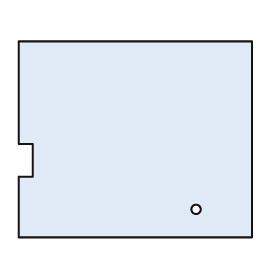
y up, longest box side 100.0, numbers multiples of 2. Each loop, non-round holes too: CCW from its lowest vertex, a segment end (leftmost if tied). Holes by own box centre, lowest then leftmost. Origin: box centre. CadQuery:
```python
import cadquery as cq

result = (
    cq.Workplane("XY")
    .moveTo(-50.0, -42.0)
    .lineTo(50.0, -42.0)
    .lineTo(50.0, 42.0)
    .lineTo(-50.0, 42.0)
    .lineTo(-50.0, -2.0)
    .lineTo(-44.0, -2.0)
    .lineTo(-44.0, -16.0)
    .lineTo(-50.0, -16.0)
    .close()
    .moveTo(26.0, -30.0)
    .circle(2.0)
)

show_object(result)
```